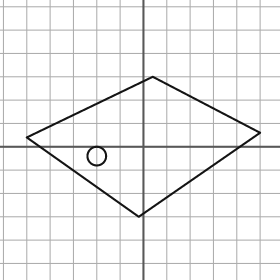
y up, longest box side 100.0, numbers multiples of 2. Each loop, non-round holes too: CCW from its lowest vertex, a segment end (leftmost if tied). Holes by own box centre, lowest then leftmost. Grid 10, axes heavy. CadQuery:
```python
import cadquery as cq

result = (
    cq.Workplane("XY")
    .moveTo(-2.0, -30.0)
    .lineTo(50.0, 6.0)
    .lineTo(4.0, 30.0)
    .lineTo(-50.0, 4.0)
    .close()
    .moveTo(-20.0, -4.0)
    .circle(4.0)
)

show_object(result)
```